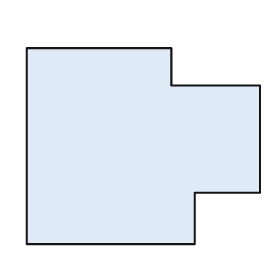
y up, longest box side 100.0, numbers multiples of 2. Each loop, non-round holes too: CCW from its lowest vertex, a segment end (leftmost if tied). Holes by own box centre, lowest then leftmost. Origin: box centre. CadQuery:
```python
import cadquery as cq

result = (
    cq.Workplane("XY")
    .moveTo(-50.0, -42.0)
    .lineTo(22.0, -42.0)
    .lineTo(22.0, -20.0)
    .lineTo(50.0, -20.0)
    .lineTo(50.0, 26.0)
    .lineTo(12.0, 26.0)
    .lineTo(12.0, 42.0)
    .lineTo(-50.0, 42.0)
    .close()
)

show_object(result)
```